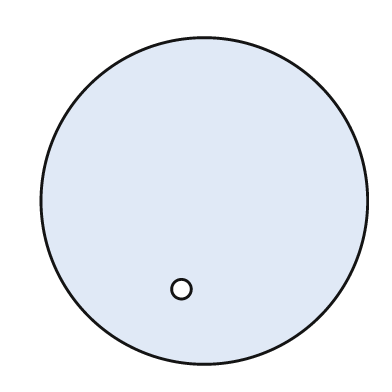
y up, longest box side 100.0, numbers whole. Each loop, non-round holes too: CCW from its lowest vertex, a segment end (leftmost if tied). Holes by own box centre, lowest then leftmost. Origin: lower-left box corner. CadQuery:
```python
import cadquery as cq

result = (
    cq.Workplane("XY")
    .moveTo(50.0, 50.0)
    .circle(50.0)
    .moveTo(43.0, 23.0)
    .circle(3.0)
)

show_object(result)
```